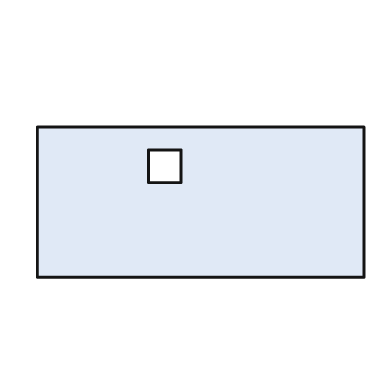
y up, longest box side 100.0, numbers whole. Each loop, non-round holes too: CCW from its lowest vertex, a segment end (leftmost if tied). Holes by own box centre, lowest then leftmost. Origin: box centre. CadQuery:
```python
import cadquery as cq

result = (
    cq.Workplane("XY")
    .moveTo(-50.0, -23.0)
    .lineTo(50.0, -23.0)
    .lineTo(50.0, 23.0)
    .lineTo(-50.0, 23.0)
    .close()
    .moveTo(-16.0, 6.0)
    .lineTo(-6.0, 6.0)
    .lineTo(-6.0, 16.0)
    .lineTo(-16.0, 16.0)
    .close()
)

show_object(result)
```